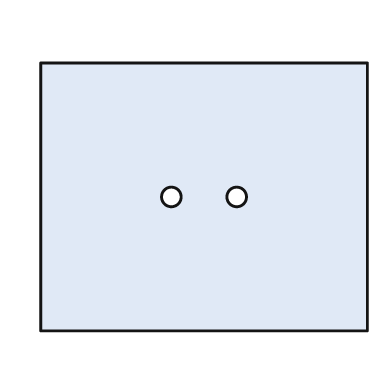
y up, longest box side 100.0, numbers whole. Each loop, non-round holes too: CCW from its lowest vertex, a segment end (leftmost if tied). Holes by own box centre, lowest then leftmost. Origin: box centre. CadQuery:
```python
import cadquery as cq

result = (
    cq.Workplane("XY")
    .moveTo(-50.0, -41.0)
    .lineTo(50.0, -41.0)
    .lineTo(50.0, 41.0)
    .lineTo(-50.0, 41.0)
    .close()
    .moveTo(-10.0, 0.0)
    .circle(3.0)
    .moveTo(10.0, 0.0)
    .circle(3.0)
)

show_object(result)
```